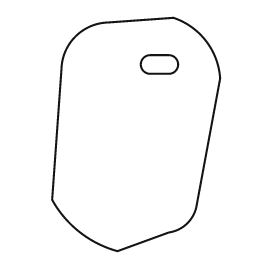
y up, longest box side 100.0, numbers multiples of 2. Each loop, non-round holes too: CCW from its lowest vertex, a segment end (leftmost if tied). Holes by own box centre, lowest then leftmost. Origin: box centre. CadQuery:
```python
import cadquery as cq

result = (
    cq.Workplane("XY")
    .moveTo(-8.0, -50.0)
    .lineTo(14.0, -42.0)
    .threePointArc((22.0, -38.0), (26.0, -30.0))
    .lineTo(36.0, 24.0)
    .threePointArc((30.0, 40.0), (16.0, 50.0))
    .lineTo(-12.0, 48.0)
    .threePointArc((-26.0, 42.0), (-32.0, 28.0))
    .lineTo(-36.0, -28.0)
    .threePointArc((-24.0, -42.0), (-8.0, -50.0))
    .close()
    .moveTo(6.0, 26.0)
    .lineTo(14.0, 26.0)
    .threePointArc((18.0, 30.0), (14.0, 34.0))
    .lineTo(6.0, 34.0)
    .threePointArc((2.0, 30.0), (6.0, 26.0))
    .close()
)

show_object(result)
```